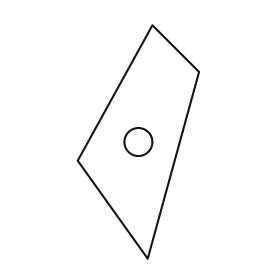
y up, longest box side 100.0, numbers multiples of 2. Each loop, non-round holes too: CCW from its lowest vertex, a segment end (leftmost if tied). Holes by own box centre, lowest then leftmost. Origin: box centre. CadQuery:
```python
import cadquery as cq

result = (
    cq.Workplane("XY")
    .moveTo(4.0, -50.0)
    .lineTo(26.0, 30.0)
    .lineTo(6.0, 50.0)
    .lineTo(-26.0, -8.0)
    .close()
    .moveTo(0.0, 0.0)
    .circle(6.0)
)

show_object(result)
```